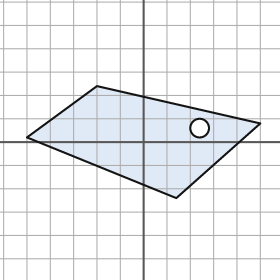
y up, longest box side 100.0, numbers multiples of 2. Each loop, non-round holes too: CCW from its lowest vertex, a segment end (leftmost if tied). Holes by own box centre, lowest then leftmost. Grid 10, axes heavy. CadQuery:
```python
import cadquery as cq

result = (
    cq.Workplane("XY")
    .moveTo(14.0, -24.0)
    .lineTo(50.0, 8.0)
    .lineTo(-20.0, 24.0)
    .lineTo(-50.0, 2.0)
    .close()
    .moveTo(24.0, 6.0)
    .circle(4.0)
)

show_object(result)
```